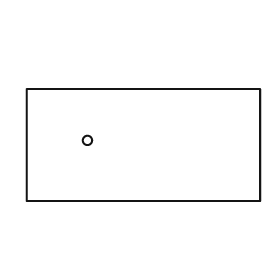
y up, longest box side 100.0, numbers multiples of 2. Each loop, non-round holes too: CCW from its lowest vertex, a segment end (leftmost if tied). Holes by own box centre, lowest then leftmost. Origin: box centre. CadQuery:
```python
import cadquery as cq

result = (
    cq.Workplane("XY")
    .moveTo(-50.0, -24.0)
    .lineTo(50.0, -24.0)
    .lineTo(50.0, 24.0)
    .lineTo(-50.0, 24.0)
    .close()
    .moveTo(-24.0, 2.0)
    .circle(2.0)
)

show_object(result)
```